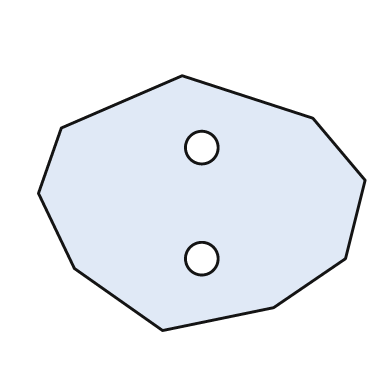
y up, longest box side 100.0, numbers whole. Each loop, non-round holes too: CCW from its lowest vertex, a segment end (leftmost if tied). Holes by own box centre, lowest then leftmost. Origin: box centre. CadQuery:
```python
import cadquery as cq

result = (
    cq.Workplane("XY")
    .moveTo(-12.0, -39.0)
    .lineTo(22.0, -32.0)
    .lineTo(44.0, -17.0)
    .lineTo(50.0, 7.0)
    .lineTo(34.0, 26.0)
    .lineTo(-6.0, 39.0)
    .lineTo(-43.0, 23.0)
    .lineTo(-50.0, 3.0)
    .lineTo(-39.0, -20.0)
    .close()
    .moveTo(0.0, -17.0)
    .circle(5.0)
    .moveTo(0.0, 17.0)
    .circle(5.0)
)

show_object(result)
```